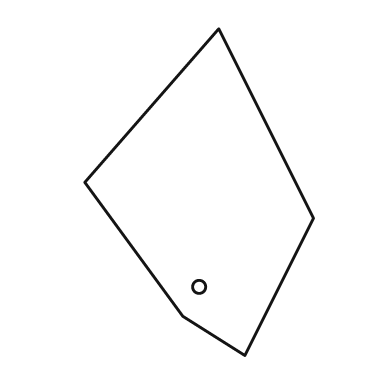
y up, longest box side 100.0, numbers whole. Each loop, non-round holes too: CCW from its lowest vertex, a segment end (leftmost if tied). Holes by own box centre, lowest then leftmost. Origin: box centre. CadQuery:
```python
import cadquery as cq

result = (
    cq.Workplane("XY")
    .moveTo(14.0, -50.0)
    .lineTo(35.0, -8.0)
    .lineTo(6.0, 50.0)
    .lineTo(-35.0, 3.0)
    .lineTo(-5.0, -38.0)
    .close()
    .moveTo(0.0, -29.0)
    .circle(2.0)
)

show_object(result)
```